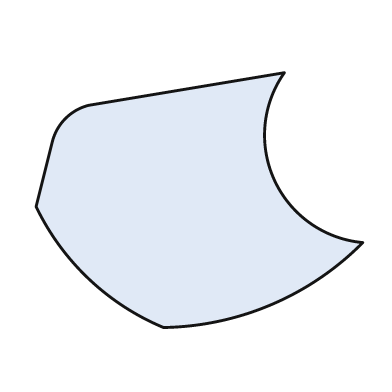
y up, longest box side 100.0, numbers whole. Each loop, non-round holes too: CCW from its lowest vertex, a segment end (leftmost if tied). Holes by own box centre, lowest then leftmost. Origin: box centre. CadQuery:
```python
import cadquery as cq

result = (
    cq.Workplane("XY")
    .moveTo(-11.0, -39.0)
    .threePointArc((22.0, -32.0), (50.0, -13.0))
    .threePointArc((23.0, 6.0), (26.0, 39.0))
    .lineTo(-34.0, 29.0)
    .threePointArc((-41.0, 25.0), (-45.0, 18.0))
    .lineTo(-50.0, -2.0)
    .threePointArc((-34.0, -24.0), (-11.0, -39.0))
    .close()
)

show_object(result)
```